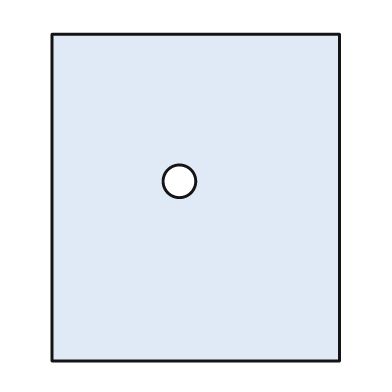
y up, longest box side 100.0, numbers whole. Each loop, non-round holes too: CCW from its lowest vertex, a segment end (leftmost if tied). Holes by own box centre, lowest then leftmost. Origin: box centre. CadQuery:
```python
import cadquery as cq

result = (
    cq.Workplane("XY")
    .moveTo(-44.0, -50.0)
    .lineTo(44.0, -50.0)
    .lineTo(44.0, 50.0)
    .lineTo(-44.0, 50.0)
    .close()
    .moveTo(-5.0, 5.0)
    .circle(5.0)
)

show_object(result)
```